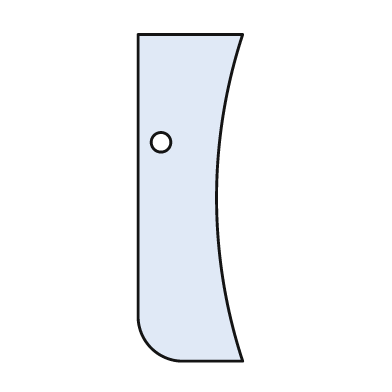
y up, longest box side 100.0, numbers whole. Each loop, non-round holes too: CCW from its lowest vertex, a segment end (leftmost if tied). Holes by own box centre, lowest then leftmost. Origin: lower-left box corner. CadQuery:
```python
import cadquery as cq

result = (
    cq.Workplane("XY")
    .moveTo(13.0, 0.0)
    .lineTo(32.0, 0.0)
    .threePointArc((24.0, 50.0), (32.0, 100.0))
    .lineTo(0.0, 100.0)
    .lineTo(0.0, 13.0)
    .threePointArc((4.0, 4.0), (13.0, 0.0))
    .close()
    .moveTo(7.0, 67.0)
    .circle(3.0)
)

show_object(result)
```